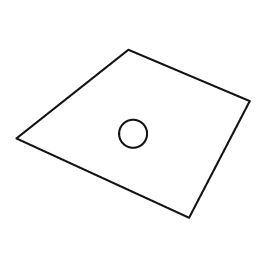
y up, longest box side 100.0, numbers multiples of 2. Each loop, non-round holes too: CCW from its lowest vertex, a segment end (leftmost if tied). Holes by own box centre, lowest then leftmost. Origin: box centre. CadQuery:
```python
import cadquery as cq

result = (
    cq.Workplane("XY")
    .moveTo(24.0, -36.0)
    .lineTo(50.0, 14.0)
    .lineTo(-2.0, 36.0)
    .lineTo(-50.0, -2.0)
    .close()
    .moveTo(0.0, 0.0)
    .circle(6.0)
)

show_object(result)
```